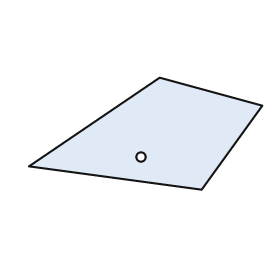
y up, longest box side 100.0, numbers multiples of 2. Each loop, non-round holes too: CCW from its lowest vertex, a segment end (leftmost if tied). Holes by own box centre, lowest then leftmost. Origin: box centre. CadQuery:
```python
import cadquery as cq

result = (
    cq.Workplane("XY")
    .moveTo(24.0, -24.0)
    .lineTo(50.0, 12.0)
    .lineTo(6.0, 24.0)
    .lineTo(-50.0, -14.0)
    .close()
    .moveTo(-2.0, -10.0)
    .circle(2.0)
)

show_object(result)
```